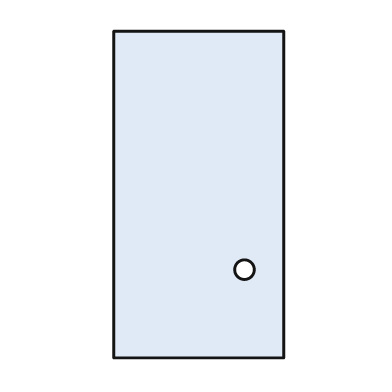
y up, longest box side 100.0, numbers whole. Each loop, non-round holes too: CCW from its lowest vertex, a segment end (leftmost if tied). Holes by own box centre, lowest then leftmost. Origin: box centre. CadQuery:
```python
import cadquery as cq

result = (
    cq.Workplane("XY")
    .moveTo(-26.0, -50.0)
    .lineTo(26.0, -50.0)
    .lineTo(26.0, 50.0)
    .lineTo(-26.0, 50.0)
    .close()
    .moveTo(14.0, -23.0)
    .circle(3.0)
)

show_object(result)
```